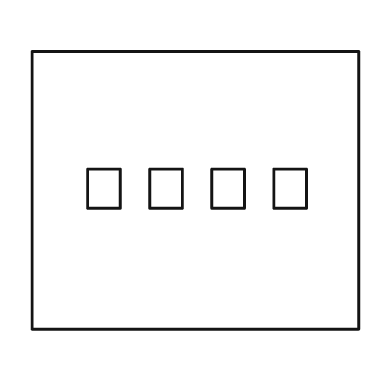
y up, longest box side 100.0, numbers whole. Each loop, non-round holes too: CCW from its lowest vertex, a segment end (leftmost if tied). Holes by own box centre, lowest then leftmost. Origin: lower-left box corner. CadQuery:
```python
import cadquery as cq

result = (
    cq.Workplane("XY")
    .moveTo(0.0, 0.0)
    .lineTo(100.0, 0.0)
    .lineTo(100.0, 85.0)
    .lineTo(0.0, 85.0)
    .close()
    .moveTo(17.0, 37.0)
    .lineTo(27.0, 37.0)
    .lineTo(27.0, 49.0)
    .lineTo(17.0, 49.0)
    .close()
    .moveTo(36.0, 37.0)
    .lineTo(46.0, 37.0)
    .lineTo(46.0, 49.0)
    .lineTo(36.0, 49.0)
    .close()
    .moveTo(55.0, 37.0)
    .lineTo(65.0, 37.0)
    .lineTo(65.0, 49.0)
    .lineTo(55.0, 49.0)
    .close()
    .moveTo(74.0, 37.0)
    .lineTo(84.0, 37.0)
    .lineTo(84.0, 49.0)
    .lineTo(74.0, 49.0)
    .close()
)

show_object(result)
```